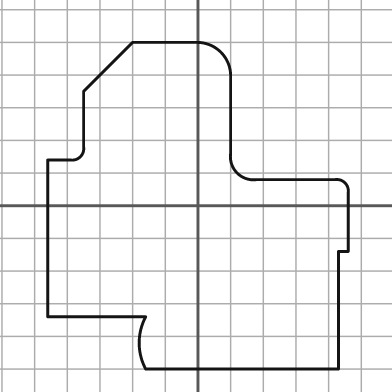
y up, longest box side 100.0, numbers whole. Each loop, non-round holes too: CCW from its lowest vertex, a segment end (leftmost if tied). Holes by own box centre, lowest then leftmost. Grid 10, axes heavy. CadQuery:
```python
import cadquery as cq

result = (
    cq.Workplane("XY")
    .moveTo(-16.0, -50.0)
    .lineTo(43.0, -50.0)
    .lineTo(43.0, -14.0)
    .lineTo(46.0, -14.0)
    .lineTo(46.0, 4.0)
    .threePointArc((45.0, 7.0), (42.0, 8.0))
    .lineTo(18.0, 8.0)
    .threePointArc((12.0, 10.0), (10.0, 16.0))
    .lineTo(10.0, 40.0)
    .threePointArc((7.0, 47.0), (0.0, 50.0))
    .lineTo(-20.0, 50.0)
    .lineTo(-35.0, 35.0)
    .lineTo(-35.0, 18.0)
    .threePointArc((-36.0, 15.0), (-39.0, 14.0))
    .lineTo(-46.0, 14.0)
    .lineTo(-46.0, -34.0)
    .lineTo(-16.0, -34.0)
    .threePointArc((-18.0, -42.0), (-16.0, -50.0))
    .close()
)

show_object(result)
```